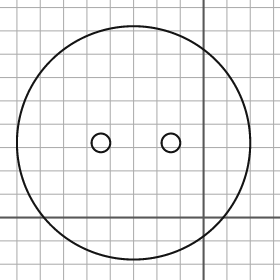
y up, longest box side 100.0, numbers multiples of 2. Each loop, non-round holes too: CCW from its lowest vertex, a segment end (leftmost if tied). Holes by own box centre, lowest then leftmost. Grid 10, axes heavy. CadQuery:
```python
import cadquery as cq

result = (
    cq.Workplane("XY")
    .moveTo(-30.0, 32.0)
    .circle(50.0)
    .moveTo(-44.0, 32.0)
    .circle(4.0)
    .moveTo(-14.0, 32.0)
    .circle(4.0)
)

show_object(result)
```